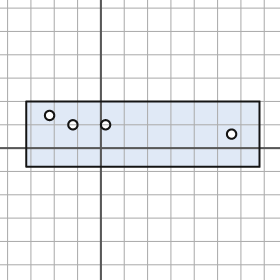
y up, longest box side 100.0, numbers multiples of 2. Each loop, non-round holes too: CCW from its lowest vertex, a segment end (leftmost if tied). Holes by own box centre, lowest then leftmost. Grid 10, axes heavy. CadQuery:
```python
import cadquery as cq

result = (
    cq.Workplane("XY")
    .moveTo(-32.0, -8.0)
    .lineTo(68.0, -8.0)
    .lineTo(68.0, 20.0)
    .lineTo(-32.0, 20.0)
    .close()
    .moveTo(56.0, 6.0)
    .circle(2.0)
    .moveTo(-12.0, 10.0)
    .circle(2.0)
    .moveTo(2.0, 10.0)
    .circle(2.0)
    .moveTo(-22.0, 14.0)
    .circle(2.0)
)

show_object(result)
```